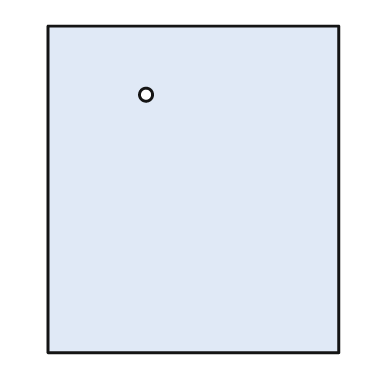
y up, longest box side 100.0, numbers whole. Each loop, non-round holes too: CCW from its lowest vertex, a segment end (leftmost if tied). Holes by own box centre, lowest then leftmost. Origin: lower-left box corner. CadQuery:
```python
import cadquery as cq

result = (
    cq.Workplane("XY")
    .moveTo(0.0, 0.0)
    .lineTo(89.0, 0.0)
    .lineTo(89.0, 100.0)
    .lineTo(0.0, 100.0)
    .close()
    .moveTo(30.0, 79.0)
    .circle(2.0)
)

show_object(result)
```